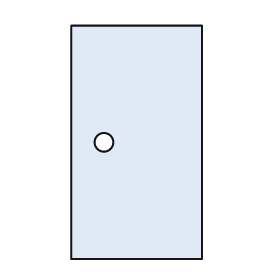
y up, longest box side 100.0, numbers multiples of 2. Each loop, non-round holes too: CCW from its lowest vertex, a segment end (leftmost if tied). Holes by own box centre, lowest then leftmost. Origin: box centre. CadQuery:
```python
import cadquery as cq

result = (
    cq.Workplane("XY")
    .moveTo(-28.0, -50.0)
    .lineTo(28.0, -50.0)
    .lineTo(28.0, 50.0)
    .lineTo(-28.0, 50.0)
    .close()
    .moveTo(-14.0, 0.0)
    .circle(4.0)
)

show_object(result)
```